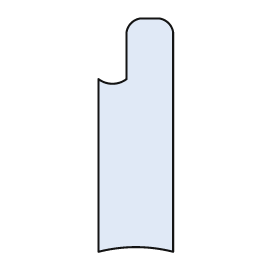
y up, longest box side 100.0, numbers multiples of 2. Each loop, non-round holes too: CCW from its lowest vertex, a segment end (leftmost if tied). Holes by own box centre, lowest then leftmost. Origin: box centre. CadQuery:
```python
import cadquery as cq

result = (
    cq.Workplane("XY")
    .moveTo(-16.0, -50.0)
    .threePointArc((0.0, -48.0), (16.0, -50.0))
    .lineTo(16.0, 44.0)
    .threePointArc((14.0, 48.0), (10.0, 50.0))
    .lineTo(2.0, 50.0)
    .threePointArc((-2.0, 48.0), (-4.0, 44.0))
    .lineTo(-4.0, 24.0)
    .threePointArc((-10.0, 22.0), (-16.0, 24.0))
    .close()
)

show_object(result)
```